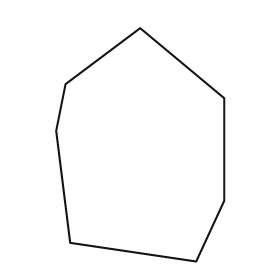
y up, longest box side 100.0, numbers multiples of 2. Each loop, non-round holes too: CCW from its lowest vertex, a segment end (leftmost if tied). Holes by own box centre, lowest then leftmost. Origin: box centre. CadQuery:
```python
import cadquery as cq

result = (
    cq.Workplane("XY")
    .moveTo(24.0, -50.0)
    .lineTo(36.0, -24.0)
    .lineTo(36.0, 20.0)
    .lineTo(0.0, 50.0)
    .lineTo(-32.0, 26.0)
    .lineTo(-36.0, 6.0)
    .lineTo(-30.0, -42.0)
    .close()
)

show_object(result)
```